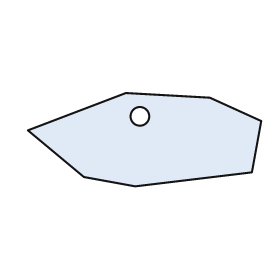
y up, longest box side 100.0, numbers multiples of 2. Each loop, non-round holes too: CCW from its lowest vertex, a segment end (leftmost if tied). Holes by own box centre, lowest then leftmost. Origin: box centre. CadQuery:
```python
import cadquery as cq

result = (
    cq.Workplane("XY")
    .moveTo(-4.0, -20.0)
    .lineTo(46.0, -14.0)
    .lineTo(50.0, 8.0)
    .lineTo(28.0, 18.0)
    .lineTo(-8.0, 20.0)
    .lineTo(-50.0, 4.0)
    .lineTo(-26.0, -16.0)
    .close()
    .moveTo(-2.0, 10.0)
    .circle(4.0)
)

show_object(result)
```